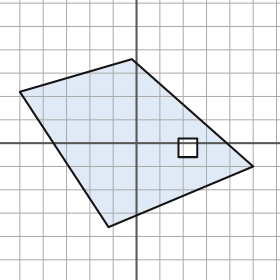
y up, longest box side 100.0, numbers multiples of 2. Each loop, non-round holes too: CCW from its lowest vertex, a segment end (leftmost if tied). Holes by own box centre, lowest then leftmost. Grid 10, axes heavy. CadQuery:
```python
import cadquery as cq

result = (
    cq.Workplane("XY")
    .moveTo(-12.0, -36.0)
    .lineTo(50.0, -10.0)
    .lineTo(-2.0, 36.0)
    .lineTo(-50.0, 22.0)
    .close()
    .moveTo(18.0, -6.0)
    .lineTo(26.0, -6.0)
    .lineTo(26.0, 2.0)
    .lineTo(18.0, 2.0)
    .close()
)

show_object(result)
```